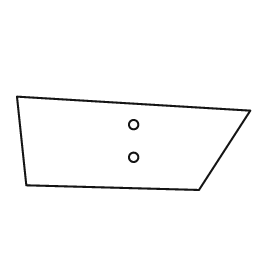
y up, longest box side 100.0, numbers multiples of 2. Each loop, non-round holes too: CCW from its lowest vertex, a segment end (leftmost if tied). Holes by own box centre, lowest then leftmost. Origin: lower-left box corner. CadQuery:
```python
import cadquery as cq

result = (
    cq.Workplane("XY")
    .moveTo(78.0, 0.0)
    .lineTo(100.0, 34.0)
    .lineTo(0.0, 40.0)
    .lineTo(4.0, 2.0)
    .close()
    .moveTo(50.0, 14.0)
    .circle(2.0)
    .moveTo(50.0, 28.0)
    .circle(2.0)
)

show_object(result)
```